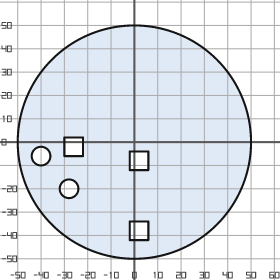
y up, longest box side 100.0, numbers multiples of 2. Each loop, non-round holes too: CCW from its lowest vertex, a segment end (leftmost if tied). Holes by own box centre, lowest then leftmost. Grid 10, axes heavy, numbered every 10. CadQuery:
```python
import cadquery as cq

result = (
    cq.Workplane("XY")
    .moveTo(0.0, 0.0)
    .circle(50.0)
    .moveTo(-2.0, -42.0)
    .lineTo(6.0, -42.0)
    .lineTo(6.0, -34.0)
    .lineTo(-2.0, -34.0)
    .close()
    .moveTo(-28.0, -20.0)
    .circle(4.0)
    .moveTo(-2.0, -12.0)
    .lineTo(6.0, -12.0)
    .lineTo(6.0, -4.0)
    .lineTo(-2.0, -4.0)
    .close()
    .moveTo(-40.0, -6.0)
    .circle(4.0)
    .moveTo(-30.0, -6.0)
    .lineTo(-22.0, -6.0)
    .lineTo(-22.0, 2.0)
    .lineTo(-30.0, 2.0)
    .close()
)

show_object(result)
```